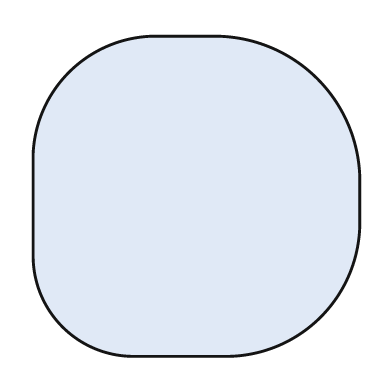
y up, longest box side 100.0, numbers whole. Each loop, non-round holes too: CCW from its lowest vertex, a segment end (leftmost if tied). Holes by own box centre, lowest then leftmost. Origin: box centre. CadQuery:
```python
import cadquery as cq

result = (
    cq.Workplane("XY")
    .moveTo(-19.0, -49.0)
    .lineTo(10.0, -49.0)
    .threePointArc((38.0, -37.0), (50.0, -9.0))
    .lineTo(50.0, 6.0)
    .threePointArc((37.0, 36.0), (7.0, 49.0))
    .lineTo(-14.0, 49.0)
    .threePointArc((-39.0, 38.0), (-50.0, 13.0))
    .lineTo(-50.0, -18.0)
    .threePointArc((-41.0, -40.0), (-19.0, -49.0))
    .close()
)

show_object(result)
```